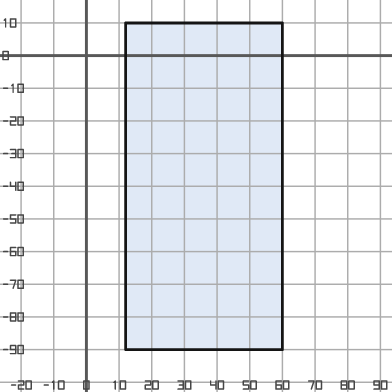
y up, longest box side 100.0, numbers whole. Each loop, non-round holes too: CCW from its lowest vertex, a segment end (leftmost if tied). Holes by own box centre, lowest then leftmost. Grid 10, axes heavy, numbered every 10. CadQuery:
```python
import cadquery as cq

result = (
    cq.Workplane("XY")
    .moveTo(12.0, -90.0)
    .lineTo(60.0, -90.0)
    .lineTo(60.0, 10.0)
    .lineTo(12.0, 10.0)
    .close()
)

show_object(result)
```